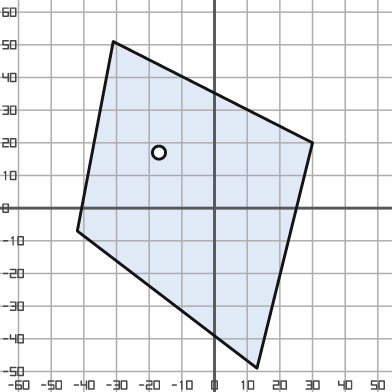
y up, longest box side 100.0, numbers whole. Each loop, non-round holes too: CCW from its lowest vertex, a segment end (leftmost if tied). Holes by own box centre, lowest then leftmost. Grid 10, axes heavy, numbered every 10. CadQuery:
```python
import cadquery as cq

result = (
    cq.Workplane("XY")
    .moveTo(13.0, -49.0)
    .lineTo(30.0, 20.0)
    .lineTo(-31.0, 51.0)
    .lineTo(-42.0, -7.0)
    .close()
    .moveTo(-17.0, 17.0)
    .circle(2.0)
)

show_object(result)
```